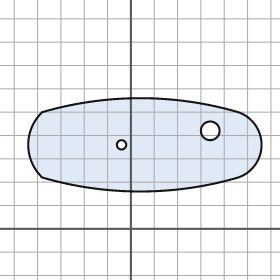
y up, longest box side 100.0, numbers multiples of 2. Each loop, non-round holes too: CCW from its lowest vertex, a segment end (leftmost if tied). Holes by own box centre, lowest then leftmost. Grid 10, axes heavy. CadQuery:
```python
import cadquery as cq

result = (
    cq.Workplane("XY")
    .moveTo(-38.0, 22.0)
    .threePointArc((4.0, 16.0), (46.0, 22.0))
    .threePointArc((56.0, 36.0), (46.0, 50.0))
    .threePointArc((4.0, 56.0), (-38.0, 50.0))
    .threePointArc((-44.0, 36.0), (-38.0, 22.0))
    .close()
    .moveTo(-4.0, 36.0)
    .circle(2.0)
    .moveTo(34.0, 42.0)
    .circle(4.0)
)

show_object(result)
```